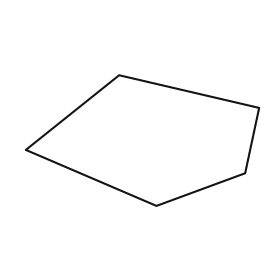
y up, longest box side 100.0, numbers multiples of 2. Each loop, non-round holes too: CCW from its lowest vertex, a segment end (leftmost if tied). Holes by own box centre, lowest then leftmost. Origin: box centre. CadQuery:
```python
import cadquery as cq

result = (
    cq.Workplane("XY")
    .moveTo(6.0, -28.0)
    .lineTo(44.0, -14.0)
    .lineTo(50.0, 14.0)
    .lineTo(-10.0, 28.0)
    .lineTo(-50.0, -4.0)
    .close()
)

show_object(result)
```